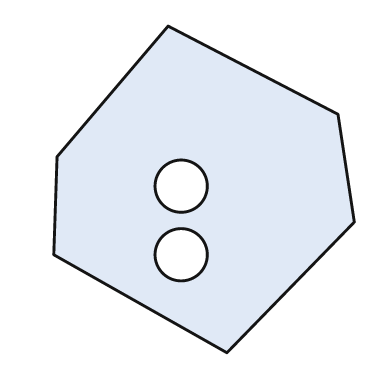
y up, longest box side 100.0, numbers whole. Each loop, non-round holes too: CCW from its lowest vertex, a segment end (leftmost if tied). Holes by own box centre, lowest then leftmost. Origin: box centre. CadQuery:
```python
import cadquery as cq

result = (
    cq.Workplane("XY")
    .moveTo(7.0, -50.0)
    .lineTo(46.0, -10.0)
    .lineTo(41.0, 23.0)
    .lineTo(-11.0, 50.0)
    .lineTo(-45.0, 10.0)
    .lineTo(-46.0, -20.0)
    .close()
    .moveTo(-7.0, -20.0)
    .circle(8.0)
    .moveTo(-7.0, 1.0)
    .circle(8.0)
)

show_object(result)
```